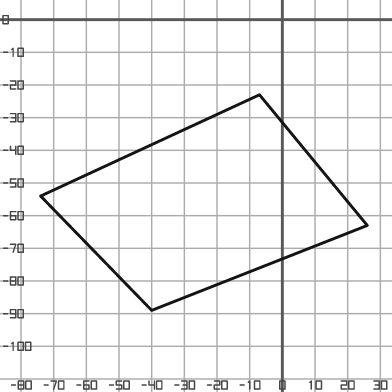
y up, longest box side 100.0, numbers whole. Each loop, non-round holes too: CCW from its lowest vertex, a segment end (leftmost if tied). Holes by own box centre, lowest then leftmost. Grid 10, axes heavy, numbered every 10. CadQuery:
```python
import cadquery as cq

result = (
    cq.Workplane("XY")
    .moveTo(-40.0, -89.0)
    .lineTo(26.0, -63.0)
    .lineTo(-7.0, -23.0)
    .lineTo(-74.0, -54.0)
    .close()
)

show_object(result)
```